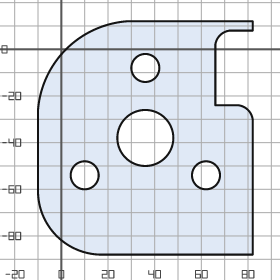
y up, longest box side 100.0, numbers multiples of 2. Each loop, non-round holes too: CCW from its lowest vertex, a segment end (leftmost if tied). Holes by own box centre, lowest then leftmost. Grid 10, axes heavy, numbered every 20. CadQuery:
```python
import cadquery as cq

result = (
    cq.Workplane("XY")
    .moveTo(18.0, -88.0)
    .lineTo(82.0, -88.0)
    .lineTo(82.0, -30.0)
    .threePointArc((80.0, -26.0), (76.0, -24.0))
    .lineTo(66.0, -24.0)
    .lineTo(66.0, 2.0)
    .threePointArc((68.0, 6.0), (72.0, 8.0))
    .lineTo(82.0, 8.0)
    .lineTo(82.0, 12.0)
    .lineTo(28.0, 12.0)
    .threePointArc((2.0, 0.0), (-10.0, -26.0))
    .lineTo(-10.0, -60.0)
    .threePointArc((-2.0, -80.0), (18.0, -88.0))
    .close()
    .moveTo(10.0, -54.0)
    .circle(6.0)
    .moveTo(62.0, -54.0)
    .circle(6.0)
    .moveTo(36.0, -38.0)
    .circle(12.0)
    .moveTo(36.0, -8.0)
    .circle(6.0)
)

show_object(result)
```